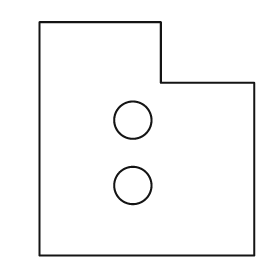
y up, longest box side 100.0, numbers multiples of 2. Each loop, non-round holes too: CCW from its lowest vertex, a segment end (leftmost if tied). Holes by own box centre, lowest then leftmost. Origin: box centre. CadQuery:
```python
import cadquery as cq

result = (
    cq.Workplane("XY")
    .moveTo(-46.0, -50.0)
    .lineTo(46.0, -50.0)
    .lineTo(46.0, 24.0)
    .lineTo(6.0, 24.0)
    .lineTo(6.0, 50.0)
    .lineTo(-46.0, 50.0)
    .close()
    .moveTo(-6.0, -20.0)
    .circle(8.0)
    .moveTo(-6.0, 8.0)
    .circle(8.0)
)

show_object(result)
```